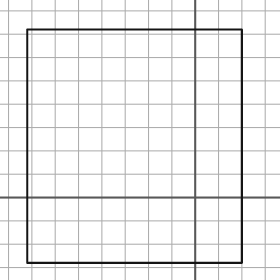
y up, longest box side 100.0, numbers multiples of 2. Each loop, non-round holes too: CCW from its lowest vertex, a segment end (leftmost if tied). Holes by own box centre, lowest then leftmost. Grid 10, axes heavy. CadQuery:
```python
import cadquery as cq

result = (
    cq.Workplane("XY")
    .moveTo(-72.0, -28.0)
    .lineTo(20.0, -28.0)
    .lineTo(20.0, 72.0)
    .lineTo(-72.0, 72.0)
    .close()
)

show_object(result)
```